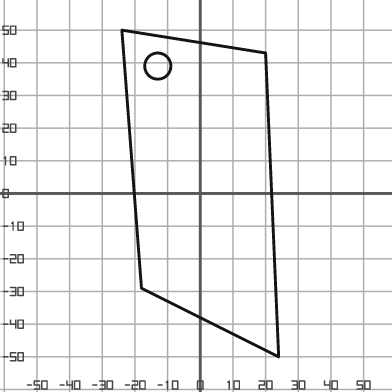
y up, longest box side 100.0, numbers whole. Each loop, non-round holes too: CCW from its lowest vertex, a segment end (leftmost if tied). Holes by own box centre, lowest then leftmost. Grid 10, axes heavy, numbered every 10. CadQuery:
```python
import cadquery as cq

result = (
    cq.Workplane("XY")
    .moveTo(24.0, -50.0)
    .lineTo(20.0, 43.0)
    .lineTo(-24.0, 50.0)
    .lineTo(-18.0, -29.0)
    .close()
    .moveTo(-13.0, 39.0)
    .circle(4.0)
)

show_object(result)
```